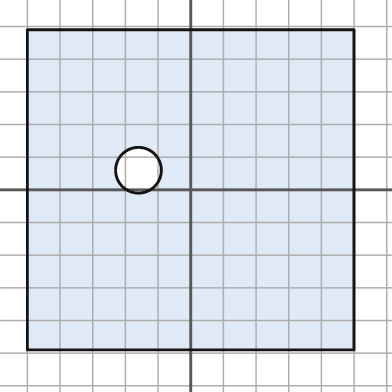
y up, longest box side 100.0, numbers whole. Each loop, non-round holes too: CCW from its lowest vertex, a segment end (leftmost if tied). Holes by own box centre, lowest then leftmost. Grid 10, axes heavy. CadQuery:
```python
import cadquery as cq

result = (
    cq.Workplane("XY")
    .moveTo(-50.0, -49.0)
    .lineTo(50.0, -49.0)
    .lineTo(50.0, 49.0)
    .lineTo(-50.0, 49.0)
    .close()
    .moveTo(-16.0, 6.0)
    .circle(7.0)
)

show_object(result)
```